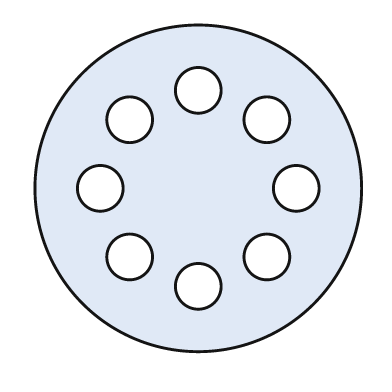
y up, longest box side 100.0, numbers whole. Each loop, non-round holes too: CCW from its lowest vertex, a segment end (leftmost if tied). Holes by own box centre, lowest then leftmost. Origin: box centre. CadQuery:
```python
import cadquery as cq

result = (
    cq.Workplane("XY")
    .moveTo(0.0, 0.0)
    .circle(50.0)
    .moveTo(0.0, -30.0)
    .circle(7.0)
    .moveTo(-21.0, -21.0)
    .circle(7.0)
    .moveTo(21.0, -21.0)
    .circle(7.0)
    .moveTo(-30.0, 0.0)
    .circle(7.0)
    .moveTo(30.0, 0.0)
    .circle(7.0)
    .moveTo(-21.0, 21.0)
    .circle(7.0)
    .moveTo(21.0, 21.0)
    .circle(7.0)
    .moveTo(0.0, 30.0)
    .circle(7.0)
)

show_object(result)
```